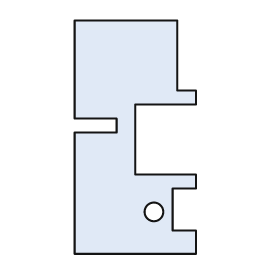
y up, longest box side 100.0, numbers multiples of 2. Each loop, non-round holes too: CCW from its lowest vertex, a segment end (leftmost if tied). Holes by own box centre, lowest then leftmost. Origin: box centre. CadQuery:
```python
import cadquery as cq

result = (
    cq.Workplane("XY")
    .moveTo(-26.0, -50.0)
    .lineTo(26.0, -50.0)
    .lineTo(26.0, -40.0)
    .lineTo(16.0, -40.0)
    .lineTo(16.0, -22.0)
    .lineTo(26.0, -22.0)
    .lineTo(26.0, -16.0)
    .lineTo(0.0, -16.0)
    .lineTo(0.0, 14.0)
    .lineTo(26.0, 14.0)
    .lineTo(26.0, 20.0)
    .lineTo(18.0, 20.0)
    .lineTo(18.0, 50.0)
    .lineTo(-26.0, 50.0)
    .lineTo(-26.0, 8.0)
    .lineTo(-8.0, 8.0)
    .lineTo(-8.0, 2.0)
    .lineTo(-26.0, 2.0)
    .close()
    .moveTo(8.0, -32.0)
    .circle(4.0)
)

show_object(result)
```